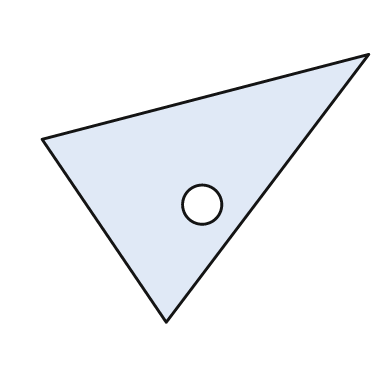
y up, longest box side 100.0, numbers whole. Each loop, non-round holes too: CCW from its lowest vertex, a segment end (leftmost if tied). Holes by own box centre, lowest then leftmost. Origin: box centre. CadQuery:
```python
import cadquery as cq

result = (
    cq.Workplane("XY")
    .moveTo(-12.0, -41.0)
    .lineTo(50.0, 41.0)
    .lineTo(-50.0, 15.0)
    .close()
    .moveTo(-1.0, -5.0)
    .circle(6.0)
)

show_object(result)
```